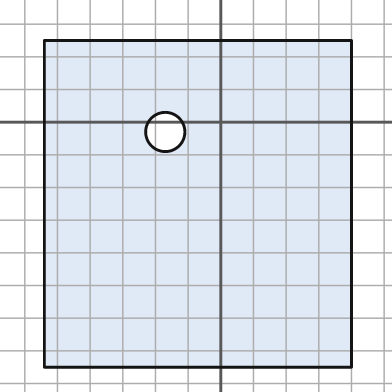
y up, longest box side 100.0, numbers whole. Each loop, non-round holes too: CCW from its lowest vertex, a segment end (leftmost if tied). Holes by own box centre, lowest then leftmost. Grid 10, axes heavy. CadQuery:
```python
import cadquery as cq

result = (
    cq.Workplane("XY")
    .moveTo(-54.0, -75.0)
    .lineTo(40.0, -75.0)
    .lineTo(40.0, 25.0)
    .lineTo(-54.0, 25.0)
    .close()
    .moveTo(-17.0, -3.0)
    .circle(6.0)
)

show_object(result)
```